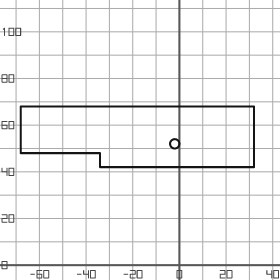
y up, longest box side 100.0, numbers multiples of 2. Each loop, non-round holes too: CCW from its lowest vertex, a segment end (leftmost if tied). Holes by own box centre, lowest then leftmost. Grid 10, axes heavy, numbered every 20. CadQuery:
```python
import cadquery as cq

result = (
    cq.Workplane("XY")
    .moveTo(-34.0, 42.0)
    .lineTo(32.0, 42.0)
    .lineTo(32.0, 68.0)
    .lineTo(-68.0, 68.0)
    .lineTo(-68.0, 48.0)
    .lineTo(-34.0, 48.0)
    .close()
    .moveTo(-2.0, 52.0)
    .circle(2.0)
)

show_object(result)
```